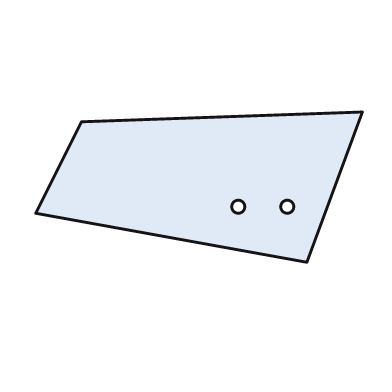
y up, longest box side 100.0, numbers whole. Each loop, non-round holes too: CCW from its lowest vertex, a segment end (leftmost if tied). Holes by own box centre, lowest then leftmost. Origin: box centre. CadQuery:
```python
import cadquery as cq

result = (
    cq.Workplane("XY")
    .moveTo(33.0, -23.0)
    .lineTo(50.0, 23.0)
    .lineTo(-36.0, 20.0)
    .lineTo(-50.0, -8.0)
    .close()
    .moveTo(12.0, -6.0)
    .circle(2.0)
    .moveTo(27.0, -6.0)
    .circle(2.0)
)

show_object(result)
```